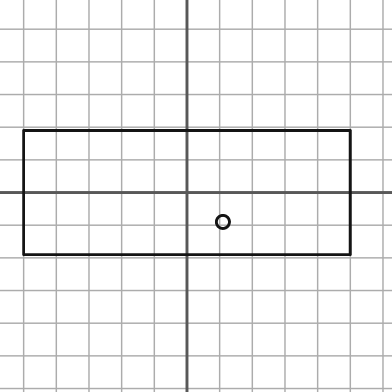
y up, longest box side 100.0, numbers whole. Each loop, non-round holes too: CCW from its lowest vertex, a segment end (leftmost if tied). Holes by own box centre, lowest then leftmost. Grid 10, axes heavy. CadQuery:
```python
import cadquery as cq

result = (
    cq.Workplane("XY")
    .moveTo(-50.0, -19.0)
    .lineTo(50.0, -19.0)
    .lineTo(50.0, 19.0)
    .lineTo(-50.0, 19.0)
    .close()
    .moveTo(11.0, -9.0)
    .circle(2.0)
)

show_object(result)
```